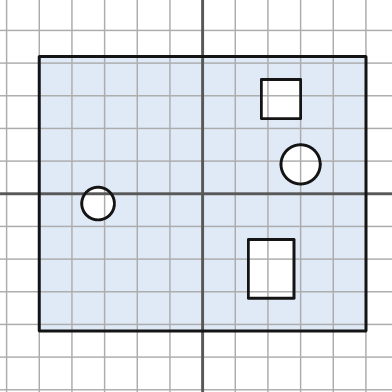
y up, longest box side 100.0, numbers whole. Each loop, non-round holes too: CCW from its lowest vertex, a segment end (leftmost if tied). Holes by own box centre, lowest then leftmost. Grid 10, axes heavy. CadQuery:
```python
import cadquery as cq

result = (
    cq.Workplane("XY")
    .moveTo(-50.0, -42.0)
    .lineTo(50.0, -42.0)
    .lineTo(50.0, 42.0)
    .lineTo(-50.0, 42.0)
    .close()
    .moveTo(14.0, -32.0)
    .lineTo(28.0, -32.0)
    .lineTo(28.0, -14.0)
    .lineTo(14.0, -14.0)
    .close()
    .moveTo(-32.0, -3.0)
    .circle(5.0)
    .moveTo(30.0, 9.0)
    .circle(6.0)
    .moveTo(18.0, 23.0)
    .lineTo(30.0, 23.0)
    .lineTo(30.0, 35.0)
    .lineTo(18.0, 35.0)
    .close()
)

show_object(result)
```